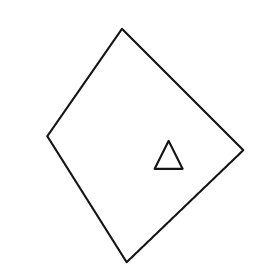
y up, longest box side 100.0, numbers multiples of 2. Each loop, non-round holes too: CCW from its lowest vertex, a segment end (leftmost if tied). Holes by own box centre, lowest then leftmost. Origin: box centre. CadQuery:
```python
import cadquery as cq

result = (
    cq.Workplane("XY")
    .moveTo(-8.0, -50.0)
    .lineTo(42.0, -2.0)
    .lineTo(-10.0, 50.0)
    .lineTo(-42.0, 4.0)
    .close()
    .moveTo(4.0, -10.0)
    .lineTo(16.0, -10.0)
    .lineTo(10.0, 2.0)
    .close()
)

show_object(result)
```